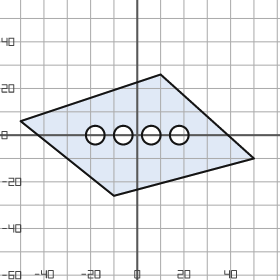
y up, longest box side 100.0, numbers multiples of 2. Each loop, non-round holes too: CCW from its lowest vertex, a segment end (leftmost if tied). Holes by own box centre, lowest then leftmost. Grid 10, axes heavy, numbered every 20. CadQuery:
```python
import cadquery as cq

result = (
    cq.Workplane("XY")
    .moveTo(-10.0, -26.0)
    .lineTo(50.0, -10.0)
    .lineTo(10.0, 26.0)
    .lineTo(-50.0, 6.0)
    .close()
    .moveTo(-18.0, 0.0)
    .circle(4.0)
    .moveTo(-6.0, 0.0)
    .circle(4.0)
    .moveTo(6.0, 0.0)
    .circle(4.0)
    .moveTo(18.0, 0.0)
    .circle(4.0)
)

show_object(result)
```